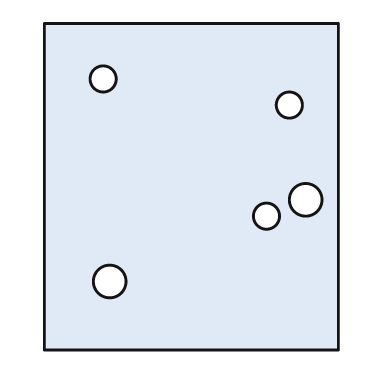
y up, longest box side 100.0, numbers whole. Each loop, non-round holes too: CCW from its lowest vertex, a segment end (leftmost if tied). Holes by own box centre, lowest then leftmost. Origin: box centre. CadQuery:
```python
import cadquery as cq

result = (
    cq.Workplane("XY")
    .moveTo(-45.0, -50.0)
    .lineTo(45.0, -50.0)
    .lineTo(45.0, 50.0)
    .lineTo(-45.0, 50.0)
    .close()
    .moveTo(-25.0, -29.0)
    .circle(5.0)
    .moveTo(23.0, -9.0)
    .circle(4.0)
    .moveTo(35.0, -4.0)
    .circle(5.0)
    .moveTo(30.0, 25.0)
    .circle(4.0)
    .moveTo(-27.0, 33.0)
    .circle(4.0)
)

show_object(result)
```